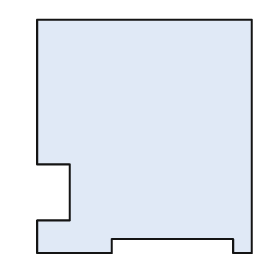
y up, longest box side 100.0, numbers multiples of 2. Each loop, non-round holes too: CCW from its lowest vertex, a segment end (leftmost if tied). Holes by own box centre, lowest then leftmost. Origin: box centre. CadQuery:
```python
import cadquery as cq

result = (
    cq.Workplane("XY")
    .moveTo(-46.0, -50.0)
    .lineTo(-14.0, -50.0)
    .lineTo(-14.0, -44.0)
    .lineTo(38.0, -44.0)
    .lineTo(38.0, -50.0)
    .lineTo(46.0, -50.0)
    .lineTo(46.0, 50.0)
    .lineTo(-46.0, 50.0)
    .lineTo(-46.0, -12.0)
    .lineTo(-32.0, -12.0)
    .lineTo(-32.0, -36.0)
    .lineTo(-46.0, -36.0)
    .close()
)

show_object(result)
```